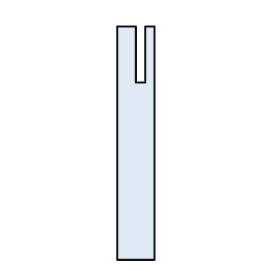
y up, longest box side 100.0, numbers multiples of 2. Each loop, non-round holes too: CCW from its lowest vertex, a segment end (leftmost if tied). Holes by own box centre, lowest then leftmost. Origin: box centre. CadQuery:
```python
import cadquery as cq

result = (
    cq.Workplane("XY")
    .moveTo(-8.0, -50.0)
    .lineTo(8.0, -50.0)
    .lineTo(8.0, 50.0)
    .lineTo(4.0, 50.0)
    .lineTo(4.0, 26.0)
    .lineTo(0.0, 26.0)
    .lineTo(0.0, 50.0)
    .lineTo(-8.0, 50.0)
    .close()
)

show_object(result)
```